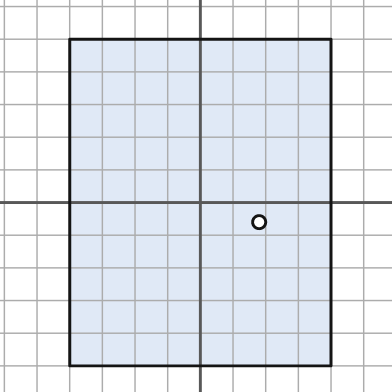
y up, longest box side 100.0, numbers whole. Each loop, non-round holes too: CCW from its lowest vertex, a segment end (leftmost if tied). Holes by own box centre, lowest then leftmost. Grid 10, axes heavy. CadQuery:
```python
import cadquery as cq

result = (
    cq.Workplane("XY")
    .moveTo(-40.0, -50.0)
    .lineTo(40.0, -50.0)
    .lineTo(40.0, 50.0)
    .lineTo(-40.0, 50.0)
    .close()
    .moveTo(18.0, -6.0)
    .circle(2.0)
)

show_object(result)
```